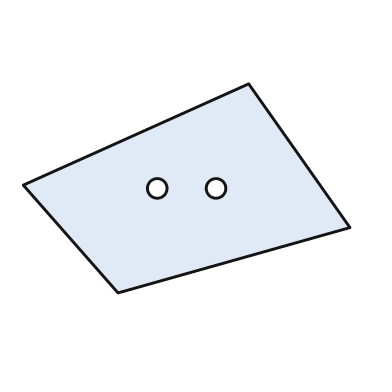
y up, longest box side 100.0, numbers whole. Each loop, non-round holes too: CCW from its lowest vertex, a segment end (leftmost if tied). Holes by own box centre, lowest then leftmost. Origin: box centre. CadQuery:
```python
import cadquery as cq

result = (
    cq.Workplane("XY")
    .moveTo(-21.0, -32.0)
    .lineTo(50.0, -12.0)
    .lineTo(19.0, 32.0)
    .lineTo(-50.0, 1.0)
    .close()
    .moveTo(-9.0, 0.0)
    .circle(3.0)
    .moveTo(9.0, 0.0)
    .circle(3.0)
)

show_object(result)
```